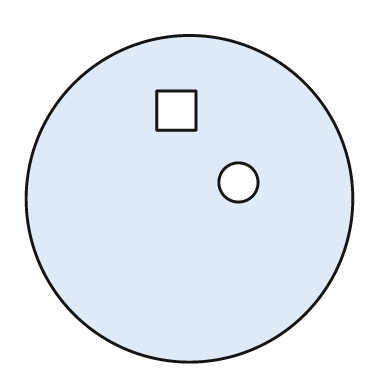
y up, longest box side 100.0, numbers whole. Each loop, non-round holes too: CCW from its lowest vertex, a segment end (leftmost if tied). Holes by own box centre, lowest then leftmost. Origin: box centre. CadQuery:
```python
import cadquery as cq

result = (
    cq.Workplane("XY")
    .moveTo(0.0, 0.0)
    .circle(50.0)
    .moveTo(15.0, 5.0)
    .circle(6.0)
    .moveTo(-10.0, 21.0)
    .lineTo(2.0, 21.0)
    .lineTo(2.0, 33.0)
    .lineTo(-10.0, 33.0)
    .close()
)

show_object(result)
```